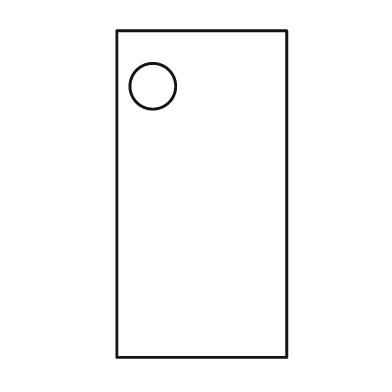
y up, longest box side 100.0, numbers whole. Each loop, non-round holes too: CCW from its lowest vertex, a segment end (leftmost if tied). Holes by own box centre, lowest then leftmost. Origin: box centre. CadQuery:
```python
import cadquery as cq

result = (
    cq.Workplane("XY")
    .moveTo(-26.0, -50.0)
    .lineTo(26.0, -50.0)
    .lineTo(26.0, 50.0)
    .lineTo(-26.0, 50.0)
    .close()
    .moveTo(-15.0, 33.0)
    .circle(7.0)
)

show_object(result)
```